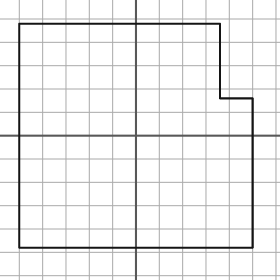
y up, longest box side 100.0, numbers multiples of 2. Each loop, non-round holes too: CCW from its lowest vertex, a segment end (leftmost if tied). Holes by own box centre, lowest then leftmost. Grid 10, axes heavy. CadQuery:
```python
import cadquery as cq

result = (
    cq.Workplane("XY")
    .moveTo(-50.0, -48.0)
    .lineTo(50.0, -48.0)
    .lineTo(50.0, 16.0)
    .lineTo(36.0, 16.0)
    .lineTo(36.0, 48.0)
    .lineTo(-50.0, 48.0)
    .close()
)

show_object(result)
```